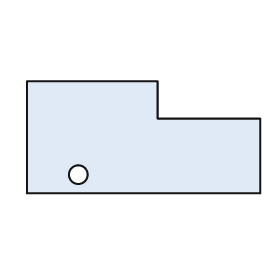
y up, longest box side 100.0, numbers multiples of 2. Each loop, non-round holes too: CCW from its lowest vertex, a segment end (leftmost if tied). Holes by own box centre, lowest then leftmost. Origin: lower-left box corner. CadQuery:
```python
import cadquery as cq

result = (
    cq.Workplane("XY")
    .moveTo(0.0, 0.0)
    .lineTo(100.0, 0.0)
    .lineTo(100.0, 32.0)
    .lineTo(56.0, 32.0)
    .lineTo(56.0, 48.0)
    .lineTo(0.0, 48.0)
    .close()
    .moveTo(22.0, 8.0)
    .circle(4.0)
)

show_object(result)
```